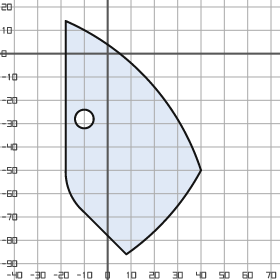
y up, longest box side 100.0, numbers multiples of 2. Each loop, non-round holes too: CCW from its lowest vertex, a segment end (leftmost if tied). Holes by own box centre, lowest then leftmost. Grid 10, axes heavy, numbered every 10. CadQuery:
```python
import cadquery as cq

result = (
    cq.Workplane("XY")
    .moveTo(8.0, -86.0)
    .threePointArc((26.0, -70.0), (40.0, -50.0))
    .threePointArc((18.0, -12.0), (-18.0, 14.0))
    .lineTo(-18.0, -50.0)
    .threePointArc((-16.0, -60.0), (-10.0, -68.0))
    .close()
    .moveTo(-10.0, -28.0)
    .circle(4.0)
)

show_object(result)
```